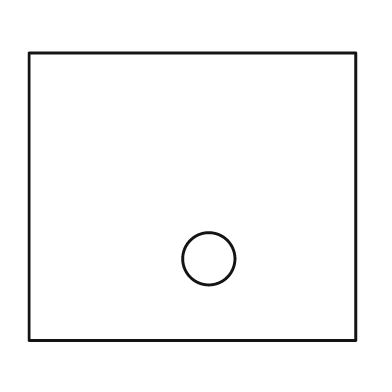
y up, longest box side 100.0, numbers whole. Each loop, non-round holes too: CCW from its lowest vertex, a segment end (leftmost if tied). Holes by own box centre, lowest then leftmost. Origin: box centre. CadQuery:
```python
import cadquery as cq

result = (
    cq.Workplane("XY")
    .moveTo(-50.0, -44.0)
    .lineTo(50.0, -44.0)
    .lineTo(50.0, 44.0)
    .lineTo(-50.0, 44.0)
    .close()
    .moveTo(5.0, -19.0)
    .circle(8.0)
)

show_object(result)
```